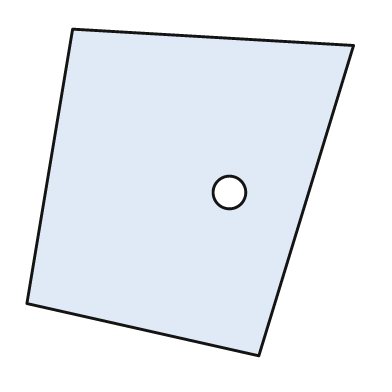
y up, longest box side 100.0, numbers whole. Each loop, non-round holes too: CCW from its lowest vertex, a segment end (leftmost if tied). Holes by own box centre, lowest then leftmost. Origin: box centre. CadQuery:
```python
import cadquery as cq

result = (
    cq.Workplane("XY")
    .moveTo(21.0, -50.0)
    .lineTo(50.0, 45.0)
    .lineTo(-36.0, 50.0)
    .lineTo(-50.0, -34.0)
    .close()
    .moveTo(12.0, 0.0)
    .circle(5.0)
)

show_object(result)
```